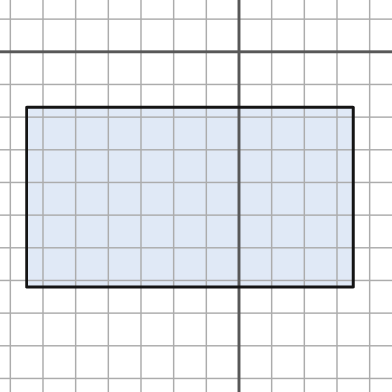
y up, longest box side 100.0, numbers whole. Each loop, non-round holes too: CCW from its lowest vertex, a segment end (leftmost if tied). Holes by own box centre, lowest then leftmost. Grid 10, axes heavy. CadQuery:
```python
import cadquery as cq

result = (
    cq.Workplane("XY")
    .moveTo(-65.0, -72.0)
    .lineTo(35.0, -72.0)
    .lineTo(35.0, -17.0)
    .lineTo(-65.0, -17.0)
    .close()
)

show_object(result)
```